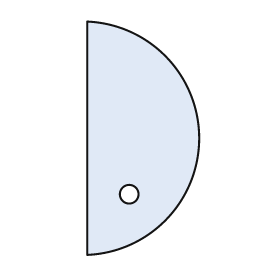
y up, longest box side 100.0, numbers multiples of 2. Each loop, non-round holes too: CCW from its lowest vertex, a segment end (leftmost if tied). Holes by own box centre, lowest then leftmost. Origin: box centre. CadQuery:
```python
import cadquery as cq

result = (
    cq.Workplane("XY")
    .moveTo(-24.0, -50.0)
    .threePointArc((24.0, 0.0), (-24.0, 50.0))
    .close()
    .moveTo(-6.0, -24.0)
    .circle(4.0)
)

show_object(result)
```